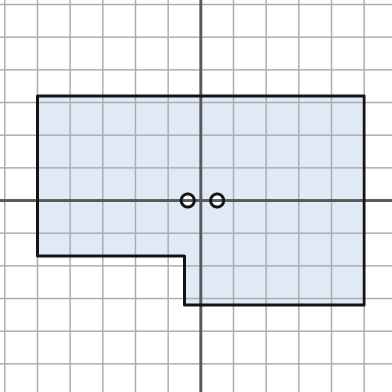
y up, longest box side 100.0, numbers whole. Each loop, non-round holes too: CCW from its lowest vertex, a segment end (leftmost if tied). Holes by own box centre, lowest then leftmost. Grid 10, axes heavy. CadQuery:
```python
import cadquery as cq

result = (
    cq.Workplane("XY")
    .moveTo(-5.0, -32.0)
    .lineTo(50.0, -32.0)
    .lineTo(50.0, 32.0)
    .lineTo(-50.0, 32.0)
    .lineTo(-50.0, -17.0)
    .lineTo(-5.0, -17.0)
    .close()
    .moveTo(-4.0, 0.0)
    .circle(2.0)
    .moveTo(5.0, 0.0)
    .circle(2.0)
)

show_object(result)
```